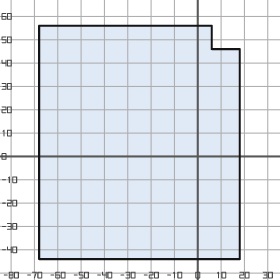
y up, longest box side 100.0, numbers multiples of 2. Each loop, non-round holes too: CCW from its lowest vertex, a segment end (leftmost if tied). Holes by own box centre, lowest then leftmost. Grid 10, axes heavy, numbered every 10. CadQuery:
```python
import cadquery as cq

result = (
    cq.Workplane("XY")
    .moveTo(-68.0, -44.0)
    .lineTo(18.0, -44.0)
    .lineTo(18.0, 46.0)
    .lineTo(6.0, 46.0)
    .lineTo(6.0, 56.0)
    .lineTo(-68.0, 56.0)
    .close()
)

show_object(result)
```